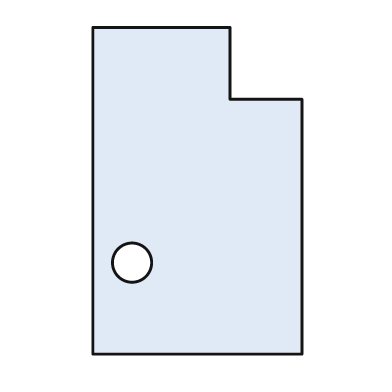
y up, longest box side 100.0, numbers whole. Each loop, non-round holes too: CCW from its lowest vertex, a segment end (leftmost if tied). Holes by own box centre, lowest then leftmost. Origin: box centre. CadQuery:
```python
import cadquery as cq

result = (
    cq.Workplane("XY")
    .moveTo(-32.0, -50.0)
    .lineTo(32.0, -50.0)
    .lineTo(32.0, 28.0)
    .lineTo(10.0, 28.0)
    .lineTo(10.0, 50.0)
    .lineTo(-32.0, 50.0)
    .close()
    .moveTo(-20.0, -22.0)
    .circle(6.0)
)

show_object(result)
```